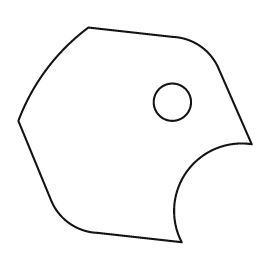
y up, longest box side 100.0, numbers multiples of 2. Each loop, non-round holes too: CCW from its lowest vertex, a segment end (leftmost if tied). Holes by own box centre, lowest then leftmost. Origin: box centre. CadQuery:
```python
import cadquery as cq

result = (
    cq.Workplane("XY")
    .moveTo(20.0, -46.0)
    .threePointArc((22.0, -16.0), (50.0, -4.0))
    .lineTo(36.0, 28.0)
    .threePointArc((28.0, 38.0), (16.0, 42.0))
    .lineTo(-20.0, 46.0)
    .threePointArc((-38.0, 28.0), (-50.0, 6.0))
    .lineTo(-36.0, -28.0)
    .threePointArc((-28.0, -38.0), (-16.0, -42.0))
    .close()
    .moveTo(16.0, 14.0)
    .circle(8.0)
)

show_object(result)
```